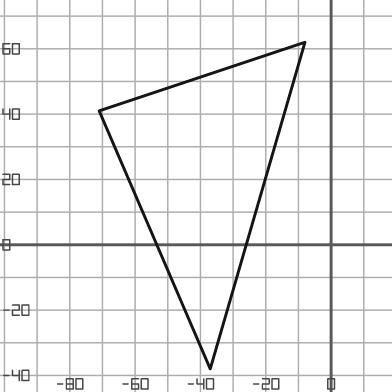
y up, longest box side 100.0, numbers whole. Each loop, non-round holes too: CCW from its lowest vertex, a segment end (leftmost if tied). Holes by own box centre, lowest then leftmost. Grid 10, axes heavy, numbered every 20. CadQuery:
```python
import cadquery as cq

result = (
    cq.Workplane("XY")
    .moveTo(-37.0, -38.0)
    .lineTo(-8.0, 62.0)
    .lineTo(-71.0, 41.0)
    .close()
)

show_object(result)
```